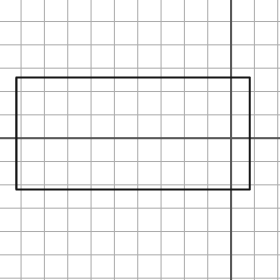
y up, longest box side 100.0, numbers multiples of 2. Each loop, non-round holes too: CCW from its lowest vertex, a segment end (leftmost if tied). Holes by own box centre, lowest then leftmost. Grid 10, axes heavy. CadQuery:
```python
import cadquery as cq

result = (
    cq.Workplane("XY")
    .moveTo(-92.0, -22.0)
    .lineTo(8.0, -22.0)
    .lineTo(8.0, 26.0)
    .lineTo(-92.0, 26.0)
    .close()
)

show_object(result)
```